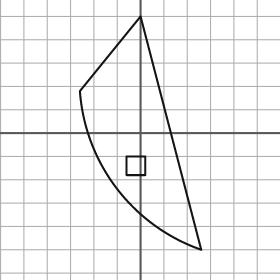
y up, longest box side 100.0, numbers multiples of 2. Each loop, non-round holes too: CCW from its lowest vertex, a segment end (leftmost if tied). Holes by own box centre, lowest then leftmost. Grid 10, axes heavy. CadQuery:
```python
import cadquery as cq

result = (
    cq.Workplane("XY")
    .moveTo(26.0, -50.0)
    .lineTo(0.0, 50.0)
    .lineTo(-26.0, 18.0)
    .threePointArc((-10.0, -24.0), (26.0, -50.0))
    .close()
    .moveTo(-6.0, -18.0)
    .lineTo(2.0, -18.0)
    .lineTo(2.0, -10.0)
    .lineTo(-6.0, -10.0)
    .close()
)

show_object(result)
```